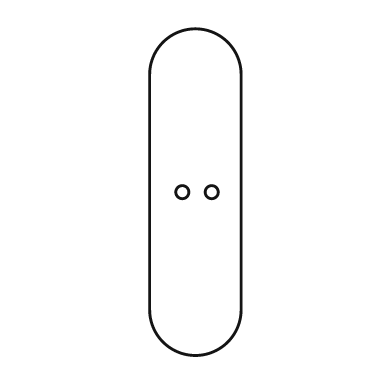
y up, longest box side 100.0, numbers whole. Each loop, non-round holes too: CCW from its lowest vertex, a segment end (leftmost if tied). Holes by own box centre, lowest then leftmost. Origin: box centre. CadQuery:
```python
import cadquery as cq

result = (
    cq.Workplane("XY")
    .moveTo(-14.0, -36.0)
    .threePointArc((0.0, -50.0), (14.0, -36.0))
    .lineTo(14.0, 36.0)
    .threePointArc((0.0, 50.0), (-14.0, 36.0))
    .close()
    .moveTo(-4.0, 0.0)
    .circle(2.0)
    .moveTo(5.0, 0.0)
    .circle(2.0)
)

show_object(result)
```